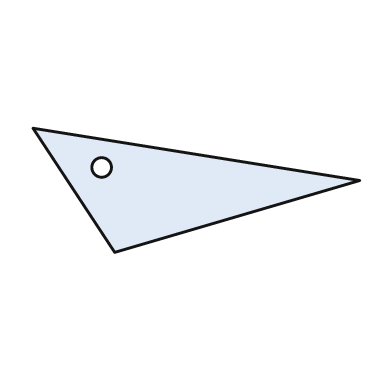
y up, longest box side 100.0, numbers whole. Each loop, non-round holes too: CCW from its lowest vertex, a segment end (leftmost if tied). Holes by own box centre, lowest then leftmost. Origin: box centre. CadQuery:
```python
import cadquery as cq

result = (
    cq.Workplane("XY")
    .moveTo(-25.0, -19.0)
    .lineTo(50.0, 3.0)
    .lineTo(-50.0, 19.0)
    .close()
    .moveTo(-29.0, 7.0)
    .circle(3.0)
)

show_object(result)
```